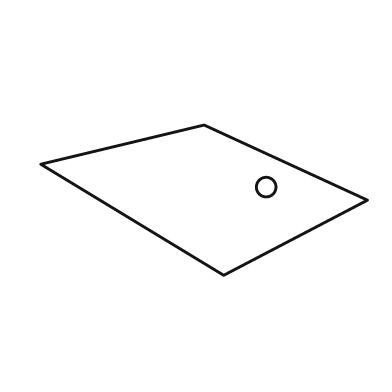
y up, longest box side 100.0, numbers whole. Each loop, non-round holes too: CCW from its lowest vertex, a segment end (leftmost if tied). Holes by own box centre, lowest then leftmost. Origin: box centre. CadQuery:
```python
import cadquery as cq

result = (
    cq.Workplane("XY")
    .moveTo(6.0, -23.0)
    .lineTo(50.0, 0.0)
    .lineTo(0.0, 23.0)
    .lineTo(-50.0, 11.0)
    .close()
    .moveTo(19.0, 4.0)
    .circle(3.0)
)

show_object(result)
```